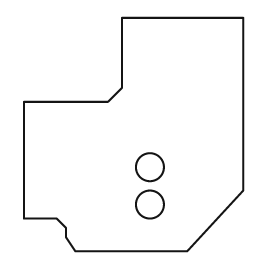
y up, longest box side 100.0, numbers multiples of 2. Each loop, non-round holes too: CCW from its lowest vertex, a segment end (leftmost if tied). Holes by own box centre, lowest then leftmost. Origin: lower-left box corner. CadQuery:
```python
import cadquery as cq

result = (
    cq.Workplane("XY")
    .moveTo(22.0, 0.0)
    .lineTo(70.0, 0.0)
    .lineTo(94.0, 26.0)
    .lineTo(94.0, 100.0)
    .lineTo(42.0, 100.0)
    .lineTo(42.0, 70.0)
    .lineTo(36.0, 64.0)
    .lineTo(0.0, 64.0)
    .lineTo(0.0, 14.0)
    .lineTo(14.0, 14.0)
    .lineTo(18.0, 10.0)
    .lineTo(18.0, 6.0)
    .close()
    .moveTo(54.0, 20.0)
    .circle(6.0)
    .moveTo(54.0, 36.0)
    .circle(6.0)
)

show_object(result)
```